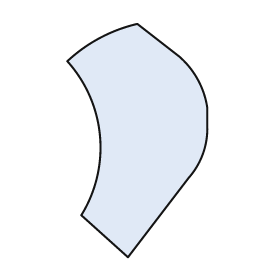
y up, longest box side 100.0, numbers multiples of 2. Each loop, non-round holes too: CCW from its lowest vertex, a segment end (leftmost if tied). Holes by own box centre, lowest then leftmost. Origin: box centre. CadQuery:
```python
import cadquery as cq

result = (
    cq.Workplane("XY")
    .moveTo(-4.0, -50.0)
    .lineTo(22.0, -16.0)
    .threePointArc((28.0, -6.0), (30.0, 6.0))
    .lineTo(30.0, 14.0)
    .threePointArc((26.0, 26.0), (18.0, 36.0))
    .lineTo(0.0, 50.0)
    .threePointArc((-16.0, 44.0), (-30.0, 34.0))
    .threePointArc((-16.0, 2.0), (-24.0, -32.0))
    .close()
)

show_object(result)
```